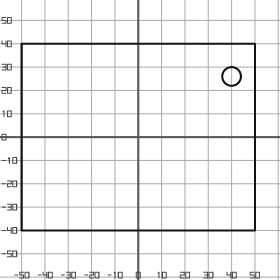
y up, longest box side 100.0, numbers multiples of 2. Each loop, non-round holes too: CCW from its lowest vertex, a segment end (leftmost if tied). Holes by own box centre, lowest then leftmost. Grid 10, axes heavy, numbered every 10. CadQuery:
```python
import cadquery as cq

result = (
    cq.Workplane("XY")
    .moveTo(-50.0, -40.0)
    .lineTo(50.0, -40.0)
    .lineTo(50.0, 40.0)
    .lineTo(-50.0, 40.0)
    .close()
    .moveTo(40.0, 26.0)
    .circle(4.0)
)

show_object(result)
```